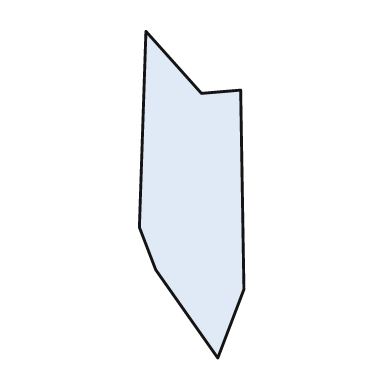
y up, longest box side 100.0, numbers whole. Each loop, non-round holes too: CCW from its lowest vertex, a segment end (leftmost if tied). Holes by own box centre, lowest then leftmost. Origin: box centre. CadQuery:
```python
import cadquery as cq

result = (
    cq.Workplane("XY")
    .moveTo(8.0, -50.0)
    .lineTo(16.0, -29.0)
    .lineTo(15.0, 32.0)
    .lineTo(3.0, 31.0)
    .lineTo(-14.0, 50.0)
    .lineTo(-16.0, -10.0)
    .lineTo(-11.0, -23.0)
    .close()
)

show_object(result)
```